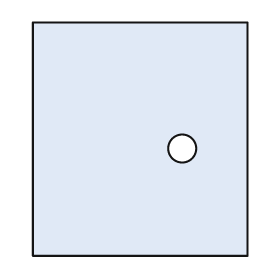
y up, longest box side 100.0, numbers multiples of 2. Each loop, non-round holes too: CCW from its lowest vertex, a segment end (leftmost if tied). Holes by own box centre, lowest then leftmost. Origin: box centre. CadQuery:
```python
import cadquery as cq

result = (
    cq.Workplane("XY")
    .moveTo(-46.0, -50.0)
    .lineTo(46.0, -50.0)
    .lineTo(46.0, 50.0)
    .lineTo(-46.0, 50.0)
    .close()
    .moveTo(18.0, -4.0)
    .circle(6.0)
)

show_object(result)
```